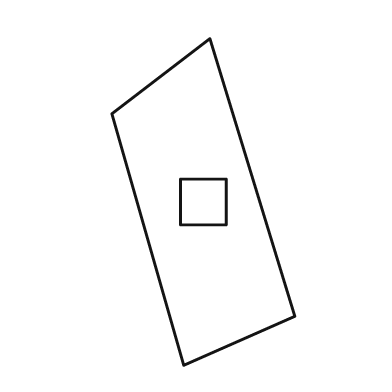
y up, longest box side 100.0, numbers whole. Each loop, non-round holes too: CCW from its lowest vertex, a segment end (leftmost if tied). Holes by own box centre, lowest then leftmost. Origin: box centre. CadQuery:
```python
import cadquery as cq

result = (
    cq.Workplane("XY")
    .moveTo(-6.0, -50.0)
    .lineTo(28.0, -35.0)
    .lineTo(2.0, 50.0)
    .lineTo(-28.0, 27.0)
    .close()
    .moveTo(-7.0, -7.0)
    .lineTo(7.0, -7.0)
    .lineTo(7.0, 7.0)
    .lineTo(-7.0, 7.0)
    .close()
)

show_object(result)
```